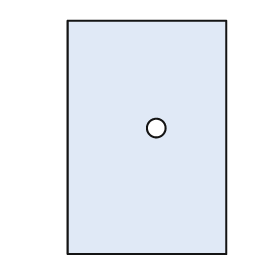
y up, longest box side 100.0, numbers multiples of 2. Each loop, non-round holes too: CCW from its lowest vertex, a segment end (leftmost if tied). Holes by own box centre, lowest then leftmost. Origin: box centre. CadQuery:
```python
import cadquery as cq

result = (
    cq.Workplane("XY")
    .moveTo(-34.0, -50.0)
    .lineTo(34.0, -50.0)
    .lineTo(34.0, 50.0)
    .lineTo(-34.0, 50.0)
    .close()
    .moveTo(4.0, 4.0)
    .circle(4.0)
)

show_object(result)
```